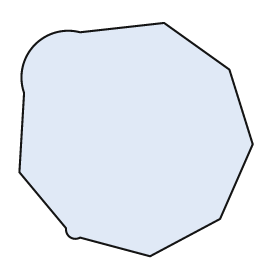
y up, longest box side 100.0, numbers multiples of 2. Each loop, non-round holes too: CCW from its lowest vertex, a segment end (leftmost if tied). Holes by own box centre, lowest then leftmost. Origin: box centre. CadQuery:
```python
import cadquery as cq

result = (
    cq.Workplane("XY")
    .moveTo(6.0, -50.0)
    .lineTo(36.0, -34.0)
    .lineTo(50.0, -2.0)
    .lineTo(40.0, 30.0)
    .lineTo(12.0, 50.0)
    .lineTo(-24.0, 46.0)
    .threePointArc((-44.0, 40.0), (-48.0, 20.0))
    .lineTo(-50.0, -14.0)
    .lineTo(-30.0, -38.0)
    .threePointArc((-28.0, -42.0), (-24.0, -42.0))
    .close()
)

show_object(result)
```